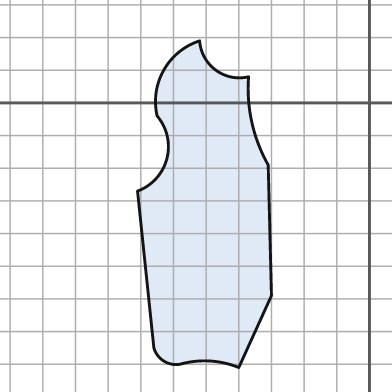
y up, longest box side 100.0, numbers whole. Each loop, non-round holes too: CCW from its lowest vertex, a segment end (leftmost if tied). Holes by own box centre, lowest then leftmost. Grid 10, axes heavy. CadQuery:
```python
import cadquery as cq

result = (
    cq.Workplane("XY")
    .moveTo(-40.0, -81.0)
    .lineTo(-30.0, -59.0)
    .lineTo(-31.0, -19.0)
    .threePointArc((-36.0, -6.0), (-37.0, 8.0))
    .threePointArc((-47.0, 10.0), (-52.0, 19.0))
    .threePointArc((-63.0, 10.0), (-65.0, -4.0))
    .threePointArc((-62.0, -17.0), (-71.0, -27.0))
    .lineTo(-66.0, -75.0)
    .threePointArc((-63.0, -79.0), (-58.0, -80.0))
    .threePointArc((-49.0, -79.0), (-40.0, -81.0))
    .close()
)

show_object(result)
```